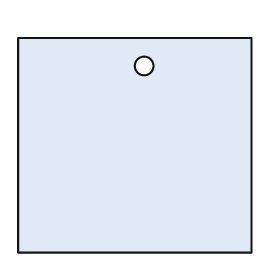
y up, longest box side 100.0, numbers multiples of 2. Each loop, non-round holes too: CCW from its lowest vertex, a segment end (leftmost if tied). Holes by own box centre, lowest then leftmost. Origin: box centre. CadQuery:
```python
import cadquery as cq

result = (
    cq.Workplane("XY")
    .moveTo(-50.0, -46.0)
    .lineTo(50.0, -46.0)
    .lineTo(50.0, 46.0)
    .lineTo(-50.0, 46.0)
    .close()
    .moveTo(4.0, 34.0)
    .circle(4.0)
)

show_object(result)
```